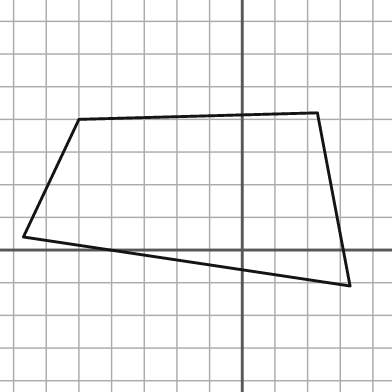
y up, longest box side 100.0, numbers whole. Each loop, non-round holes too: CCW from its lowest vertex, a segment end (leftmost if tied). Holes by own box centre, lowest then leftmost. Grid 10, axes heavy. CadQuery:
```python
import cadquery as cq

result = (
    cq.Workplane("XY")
    .moveTo(33.0, -11.0)
    .lineTo(23.0, 42.0)
    .lineTo(-50.0, 40.0)
    .lineTo(-67.0, 4.0)
    .close()
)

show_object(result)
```